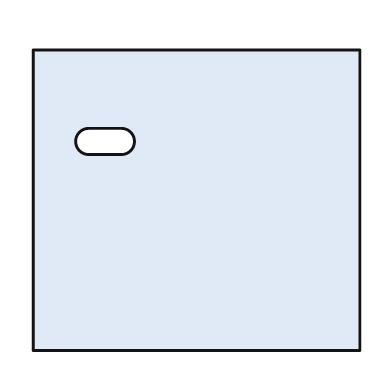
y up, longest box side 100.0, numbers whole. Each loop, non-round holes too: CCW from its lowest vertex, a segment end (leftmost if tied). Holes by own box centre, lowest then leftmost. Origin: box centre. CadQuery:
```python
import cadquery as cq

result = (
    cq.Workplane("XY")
    .moveTo(-50.0, -46.0)
    .lineTo(50.0, -46.0)
    .lineTo(50.0, 46.0)
    .lineTo(-50.0, 46.0)
    .close()
    .moveTo(-33.0, 14.0)
    .lineTo(-23.0, 14.0)
    .threePointArc((-19.0, 18.0), (-23.0, 22.0))
    .lineTo(-33.0, 22.0)
    .threePointArc((-37.0, 18.0), (-33.0, 14.0))
    .close()
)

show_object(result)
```